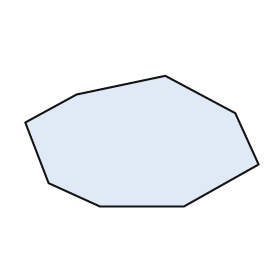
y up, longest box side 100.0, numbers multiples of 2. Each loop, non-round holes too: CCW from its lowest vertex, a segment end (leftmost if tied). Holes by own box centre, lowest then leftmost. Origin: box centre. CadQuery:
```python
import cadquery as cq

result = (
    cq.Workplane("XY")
    .moveTo(-18.0, -28.0)
    .lineTo(18.0, -28.0)
    .lineTo(50.0, -10.0)
    .lineTo(40.0, 12.0)
    .lineTo(10.0, 28.0)
    .lineTo(-28.0, 20.0)
    .lineTo(-50.0, 8.0)
    .lineTo(-40.0, -18.0)
    .close()
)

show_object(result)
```